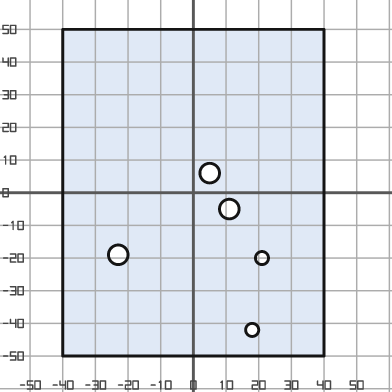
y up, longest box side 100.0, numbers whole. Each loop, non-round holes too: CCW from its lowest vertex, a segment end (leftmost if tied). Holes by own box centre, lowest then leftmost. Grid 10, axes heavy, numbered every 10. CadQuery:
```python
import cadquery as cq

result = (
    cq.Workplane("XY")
    .moveTo(-40.0, -50.0)
    .lineTo(40.0, -50.0)
    .lineTo(40.0, 50.0)
    .lineTo(-40.0, 50.0)
    .close()
    .moveTo(18.0, -42.0)
    .circle(2.0)
    .moveTo(21.0, -20.0)
    .circle(2.0)
    .moveTo(-23.0, -19.0)
    .circle(3.0)
    .moveTo(11.0, -5.0)
    .circle(3.0)
    .moveTo(5.0, 6.0)
    .circle(3.0)
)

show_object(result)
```